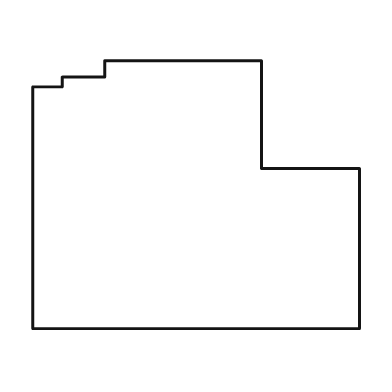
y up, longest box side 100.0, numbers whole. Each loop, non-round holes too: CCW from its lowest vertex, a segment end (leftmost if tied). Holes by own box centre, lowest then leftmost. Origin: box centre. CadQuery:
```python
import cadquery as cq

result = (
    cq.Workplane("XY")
    .moveTo(-50.0, -41.0)
    .lineTo(50.0, -41.0)
    .lineTo(50.0, 8.0)
    .lineTo(20.0, 8.0)
    .lineTo(20.0, 41.0)
    .lineTo(-28.0, 41.0)
    .lineTo(-28.0, 36.0)
    .lineTo(-41.0, 36.0)
    .lineTo(-41.0, 33.0)
    .lineTo(-50.0, 33.0)
    .close()
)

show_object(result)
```